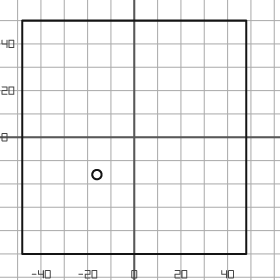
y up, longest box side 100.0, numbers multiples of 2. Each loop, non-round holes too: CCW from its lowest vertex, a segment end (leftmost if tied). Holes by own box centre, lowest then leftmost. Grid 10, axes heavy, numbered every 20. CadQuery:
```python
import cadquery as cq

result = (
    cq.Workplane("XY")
    .moveTo(-48.0, -50.0)
    .lineTo(48.0, -50.0)
    .lineTo(48.0, 50.0)
    .lineTo(-48.0, 50.0)
    .close()
    .moveTo(-16.0, -16.0)
    .circle(2.0)
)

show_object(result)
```